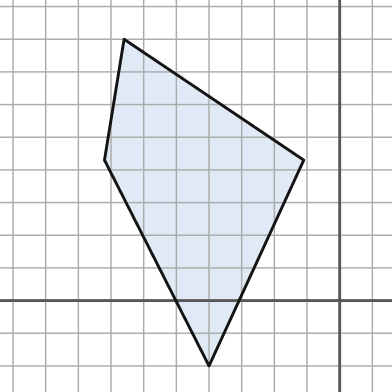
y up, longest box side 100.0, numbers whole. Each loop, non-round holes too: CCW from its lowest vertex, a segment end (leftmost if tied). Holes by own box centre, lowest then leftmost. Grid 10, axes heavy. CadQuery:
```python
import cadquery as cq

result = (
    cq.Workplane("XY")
    .moveTo(-40.0, -20.0)
    .lineTo(-11.0, 43.0)
    .lineTo(-66.0, 80.0)
    .lineTo(-72.0, 43.0)
    .close()
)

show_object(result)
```